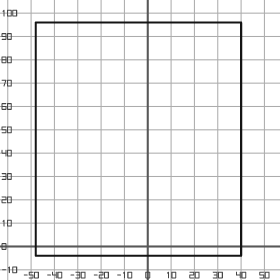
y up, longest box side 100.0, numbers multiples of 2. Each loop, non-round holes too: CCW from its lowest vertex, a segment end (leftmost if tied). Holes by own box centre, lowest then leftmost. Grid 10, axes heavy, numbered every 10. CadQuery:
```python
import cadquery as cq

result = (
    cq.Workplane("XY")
    .moveTo(-48.0, -4.0)
    .lineTo(40.0, -4.0)
    .lineTo(40.0, 96.0)
    .lineTo(-48.0, 96.0)
    .close()
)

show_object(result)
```